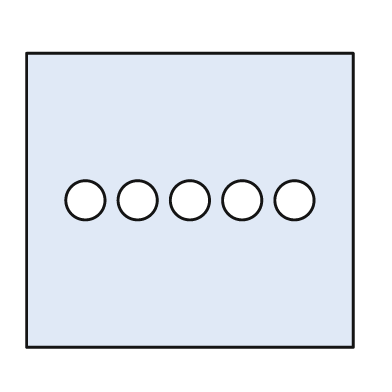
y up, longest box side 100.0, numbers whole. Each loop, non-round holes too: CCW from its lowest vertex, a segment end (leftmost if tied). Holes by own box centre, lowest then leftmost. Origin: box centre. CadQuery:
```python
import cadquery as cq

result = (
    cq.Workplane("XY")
    .moveTo(-50.0, -45.0)
    .lineTo(50.0, -45.0)
    .lineTo(50.0, 45.0)
    .lineTo(-50.0, 45.0)
    .close()
    .moveTo(-32.0, 0.0)
    .circle(6.0)
    .moveTo(-16.0, 0.0)
    .circle(6.0)
    .moveTo(0.0, 0.0)
    .circle(6.0)
    .moveTo(16.0, 0.0)
    .circle(6.0)
    .moveTo(32.0, 0.0)
    .circle(6.0)
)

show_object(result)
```